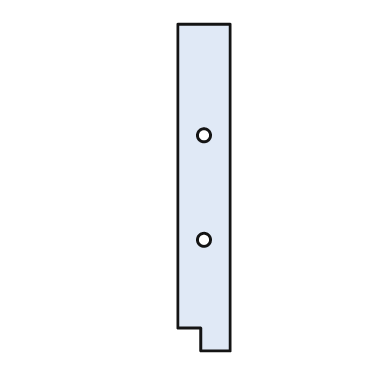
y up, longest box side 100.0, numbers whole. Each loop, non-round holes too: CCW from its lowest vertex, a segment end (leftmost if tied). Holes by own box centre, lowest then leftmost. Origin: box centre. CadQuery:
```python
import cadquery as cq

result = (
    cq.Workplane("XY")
    .moveTo(-1.0, -50.0)
    .lineTo(8.0, -50.0)
    .lineTo(8.0, 50.0)
    .lineTo(-8.0, 50.0)
    .lineTo(-8.0, -43.0)
    .lineTo(-1.0, -43.0)
    .close()
    .moveTo(0.0, -16.0)
    .circle(2.0)
    .moveTo(0.0, 16.0)
    .circle(2.0)
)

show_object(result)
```